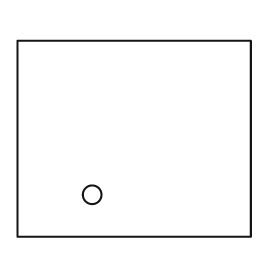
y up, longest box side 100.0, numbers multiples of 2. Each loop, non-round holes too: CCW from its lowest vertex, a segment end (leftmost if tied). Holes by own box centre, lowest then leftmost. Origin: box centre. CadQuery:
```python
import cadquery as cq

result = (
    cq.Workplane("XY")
    .moveTo(-50.0, -42.0)
    .lineTo(50.0, -42.0)
    .lineTo(50.0, 42.0)
    .lineTo(-50.0, 42.0)
    .close()
    .moveTo(-18.0, -24.0)
    .circle(4.0)
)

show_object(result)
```